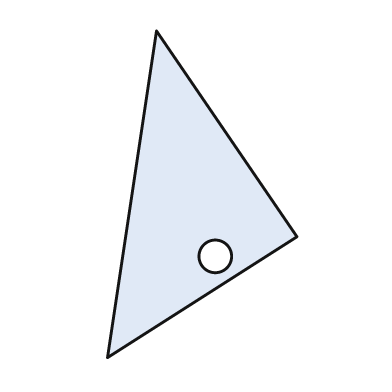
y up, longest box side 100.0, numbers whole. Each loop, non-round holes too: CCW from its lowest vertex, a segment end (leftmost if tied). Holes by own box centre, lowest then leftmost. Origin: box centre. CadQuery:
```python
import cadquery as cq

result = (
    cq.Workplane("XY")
    .moveTo(-29.0, -50.0)
    .lineTo(29.0, -13.0)
    .lineTo(-14.0, 50.0)
    .close()
    .moveTo(4.0, -19.0)
    .circle(5.0)
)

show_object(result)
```